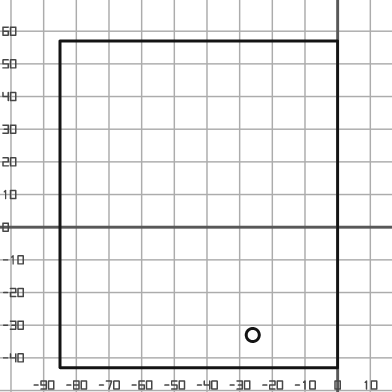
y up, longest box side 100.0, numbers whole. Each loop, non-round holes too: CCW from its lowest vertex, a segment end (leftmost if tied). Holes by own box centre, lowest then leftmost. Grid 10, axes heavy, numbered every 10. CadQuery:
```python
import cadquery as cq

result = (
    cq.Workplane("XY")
    .moveTo(-85.0, -43.0)
    .lineTo(0.0, -43.0)
    .lineTo(0.0, 57.0)
    .lineTo(-85.0, 57.0)
    .close()
    .moveTo(-26.0, -33.0)
    .circle(2.0)
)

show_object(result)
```